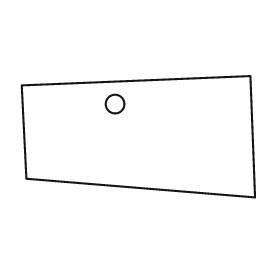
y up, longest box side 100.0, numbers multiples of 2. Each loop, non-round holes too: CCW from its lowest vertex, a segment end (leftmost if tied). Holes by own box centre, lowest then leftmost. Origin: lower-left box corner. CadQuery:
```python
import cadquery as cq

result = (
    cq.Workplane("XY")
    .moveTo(100.0, 0.0)
    .lineTo(98.0, 52.0)
    .lineTo(0.0, 48.0)
    .lineTo(2.0, 8.0)
    .close()
    .moveTo(40.0, 40.0)
    .circle(4.0)
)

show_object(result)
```